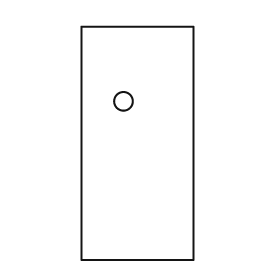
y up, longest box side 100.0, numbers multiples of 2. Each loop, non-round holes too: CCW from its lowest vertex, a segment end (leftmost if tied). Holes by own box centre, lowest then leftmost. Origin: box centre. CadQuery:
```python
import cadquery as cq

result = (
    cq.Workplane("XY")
    .moveTo(-24.0, -50.0)
    .lineTo(24.0, -50.0)
    .lineTo(24.0, 50.0)
    .lineTo(-24.0, 50.0)
    .close()
    .moveTo(-6.0, 18.0)
    .circle(4.0)
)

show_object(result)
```